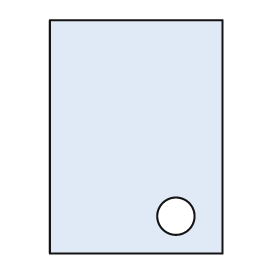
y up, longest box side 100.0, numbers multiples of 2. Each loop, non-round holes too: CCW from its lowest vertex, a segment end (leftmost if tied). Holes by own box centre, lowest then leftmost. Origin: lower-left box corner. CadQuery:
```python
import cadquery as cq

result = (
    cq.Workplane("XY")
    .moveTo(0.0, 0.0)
    .lineTo(74.0, 0.0)
    .lineTo(74.0, 100.0)
    .lineTo(0.0, 100.0)
    .close()
    .moveTo(54.0, 16.0)
    .circle(8.0)
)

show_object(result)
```